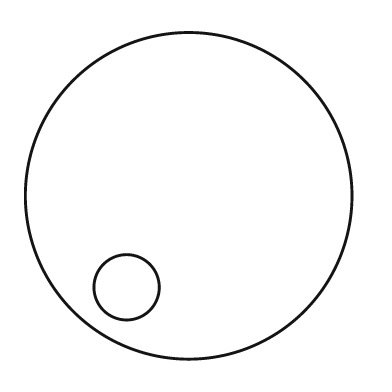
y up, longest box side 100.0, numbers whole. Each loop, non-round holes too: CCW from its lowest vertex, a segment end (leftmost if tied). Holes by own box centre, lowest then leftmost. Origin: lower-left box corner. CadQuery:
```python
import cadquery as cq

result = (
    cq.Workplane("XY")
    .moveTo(50.0, 50.0)
    .circle(50.0)
    .moveTo(31.0, 22.0)
    .circle(10.0)
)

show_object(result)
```